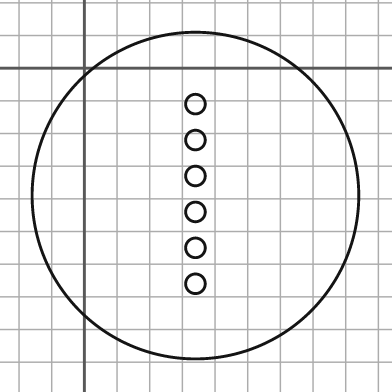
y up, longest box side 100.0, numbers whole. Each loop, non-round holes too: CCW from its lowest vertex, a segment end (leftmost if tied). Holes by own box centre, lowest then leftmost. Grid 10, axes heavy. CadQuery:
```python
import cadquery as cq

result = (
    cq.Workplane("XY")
    .moveTo(34.0, -39.0)
    .circle(50.0)
    .moveTo(34.0, -66.0)
    .circle(3.0)
    .moveTo(34.0, -55.0)
    .circle(3.0)
    .moveTo(34.0, -44.0)
    .circle(3.0)
    .moveTo(34.0, -33.0)
    .circle(3.0)
    .moveTo(34.0, -22.0)
    .circle(3.0)
    .moveTo(34.0, -11.0)
    .circle(3.0)
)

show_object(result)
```